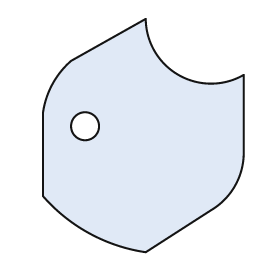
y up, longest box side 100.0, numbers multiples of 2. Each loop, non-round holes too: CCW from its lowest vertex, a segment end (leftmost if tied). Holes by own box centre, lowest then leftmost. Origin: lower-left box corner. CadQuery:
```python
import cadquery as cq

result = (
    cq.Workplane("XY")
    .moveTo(44.0, 0.0)
    .lineTo(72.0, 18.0)
    .threePointArc((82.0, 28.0), (86.0, 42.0))
    .lineTo(86.0, 76.0)
    .threePointArc((58.0, 76.0), (44.0, 100.0))
    .lineTo(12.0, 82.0)
    .threePointArc((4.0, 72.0), (0.0, 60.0))
    .lineTo(0.0, 24.0)
    .threePointArc((20.0, 8.0), (44.0, 0.0))
    .close()
    .moveTo(18.0, 54.0)
    .circle(6.0)
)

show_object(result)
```